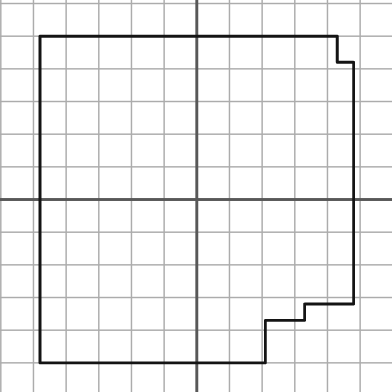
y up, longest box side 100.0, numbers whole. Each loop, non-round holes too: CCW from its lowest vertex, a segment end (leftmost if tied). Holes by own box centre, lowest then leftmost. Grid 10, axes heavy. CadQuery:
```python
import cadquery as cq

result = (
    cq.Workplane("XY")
    .moveTo(-48.0, -50.0)
    .lineTo(21.0, -50.0)
    .lineTo(21.0, -37.0)
    .lineTo(33.0, -37.0)
    .lineTo(33.0, -32.0)
    .lineTo(48.0, -32.0)
    .lineTo(48.0, 42.0)
    .lineTo(43.0, 42.0)
    .lineTo(43.0, 50.0)
    .lineTo(-48.0, 50.0)
    .close()
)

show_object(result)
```